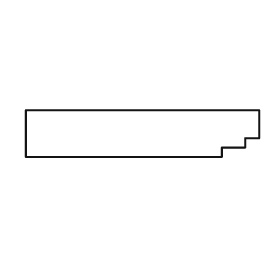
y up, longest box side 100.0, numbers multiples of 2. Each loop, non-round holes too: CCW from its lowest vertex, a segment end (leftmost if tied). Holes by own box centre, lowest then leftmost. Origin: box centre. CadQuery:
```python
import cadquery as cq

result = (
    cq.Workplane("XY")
    .moveTo(-50.0, -10.0)
    .lineTo(34.0, -10.0)
    .lineTo(34.0, -6.0)
    .lineTo(44.0, -6.0)
    .lineTo(44.0, -2.0)
    .lineTo(50.0, -2.0)
    .lineTo(50.0, 10.0)
    .lineTo(-50.0, 10.0)
    .close()
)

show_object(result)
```